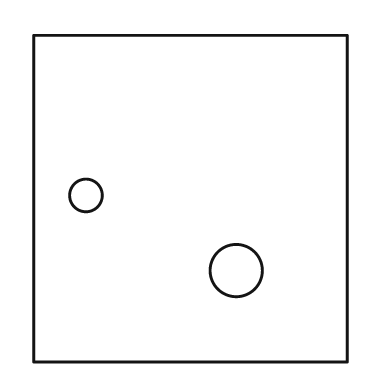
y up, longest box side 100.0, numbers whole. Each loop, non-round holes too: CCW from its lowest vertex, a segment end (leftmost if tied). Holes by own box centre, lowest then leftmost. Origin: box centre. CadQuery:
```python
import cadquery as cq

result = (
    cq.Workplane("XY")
    .moveTo(-48.0, -50.0)
    .lineTo(48.0, -50.0)
    .lineTo(48.0, 50.0)
    .lineTo(-48.0, 50.0)
    .close()
    .moveTo(14.0, -22.0)
    .circle(8.0)
    .moveTo(-32.0, 1.0)
    .circle(5.0)
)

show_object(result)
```